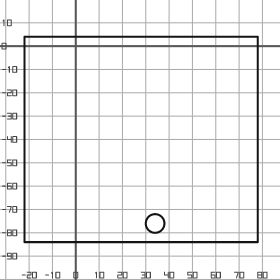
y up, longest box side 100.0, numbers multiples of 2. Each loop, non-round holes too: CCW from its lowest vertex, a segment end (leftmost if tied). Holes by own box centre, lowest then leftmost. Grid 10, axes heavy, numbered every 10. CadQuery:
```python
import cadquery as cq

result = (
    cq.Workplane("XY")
    .moveTo(-22.0, -84.0)
    .lineTo(78.0, -84.0)
    .lineTo(78.0, 4.0)
    .lineTo(-22.0, 4.0)
    .close()
    .moveTo(34.0, -76.0)
    .circle(4.0)
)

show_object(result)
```